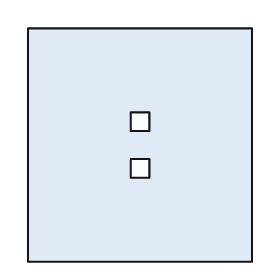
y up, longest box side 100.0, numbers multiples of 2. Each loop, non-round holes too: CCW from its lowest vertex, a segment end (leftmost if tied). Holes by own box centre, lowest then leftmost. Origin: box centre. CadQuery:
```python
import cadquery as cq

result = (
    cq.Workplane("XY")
    .moveTo(-48.0, -50.0)
    .lineTo(48.0, -50.0)
    .lineTo(48.0, 50.0)
    .lineTo(-48.0, 50.0)
    .close()
    .moveTo(-4.0, -14.0)
    .lineTo(4.0, -14.0)
    .lineTo(4.0, -6.0)
    .lineTo(-4.0, -6.0)
    .close()
    .moveTo(-4.0, 6.0)
    .lineTo(4.0, 6.0)
    .lineTo(4.0, 14.0)
    .lineTo(-4.0, 14.0)
    .close()
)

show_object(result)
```